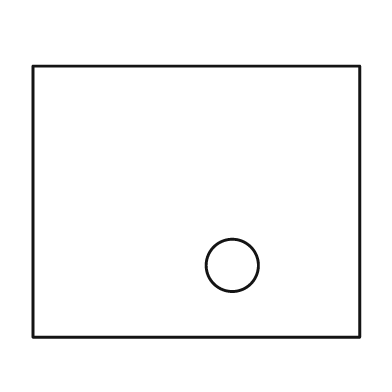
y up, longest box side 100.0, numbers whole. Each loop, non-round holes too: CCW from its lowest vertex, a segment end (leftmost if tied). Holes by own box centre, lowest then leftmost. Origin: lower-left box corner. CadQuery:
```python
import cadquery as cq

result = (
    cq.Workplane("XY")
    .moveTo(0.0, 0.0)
    .lineTo(100.0, 0.0)
    .lineTo(100.0, 83.0)
    .lineTo(0.0, 83.0)
    .close()
    .moveTo(61.0, 22.0)
    .circle(8.0)
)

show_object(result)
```